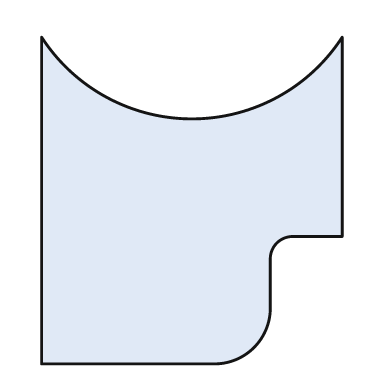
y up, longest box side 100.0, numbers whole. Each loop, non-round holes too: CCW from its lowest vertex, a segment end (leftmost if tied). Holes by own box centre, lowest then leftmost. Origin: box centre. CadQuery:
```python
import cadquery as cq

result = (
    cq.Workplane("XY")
    .moveTo(-46.0, -50.0)
    .lineTo(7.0, -50.0)
    .threePointArc((19.0, -45.0), (24.0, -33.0))
    .lineTo(24.0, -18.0)
    .threePointArc((26.0, -13.0), (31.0, -11.0))
    .lineTo(46.0, -11.0)
    .lineTo(46.0, 50.0)
    .threePointArc((0.0, 25.0), (-46.0, 50.0))
    .close()
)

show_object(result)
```